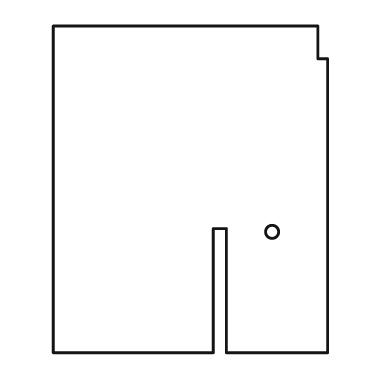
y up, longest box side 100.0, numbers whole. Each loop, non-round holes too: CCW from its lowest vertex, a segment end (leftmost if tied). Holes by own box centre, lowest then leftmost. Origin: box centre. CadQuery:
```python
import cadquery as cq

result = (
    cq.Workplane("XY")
    .moveTo(-42.0, -50.0)
    .lineTo(7.0, -50.0)
    .lineTo(7.0, -12.0)
    .lineTo(11.0, -12.0)
    .lineTo(11.0, -50.0)
    .lineTo(42.0, -50.0)
    .lineTo(42.0, 40.0)
    .lineTo(39.0, 40.0)
    .lineTo(39.0, 50.0)
    .lineTo(-42.0, 50.0)
    .close()
    .moveTo(25.0, -13.0)
    .circle(2.0)
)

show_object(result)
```